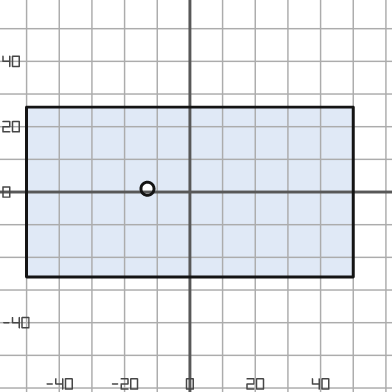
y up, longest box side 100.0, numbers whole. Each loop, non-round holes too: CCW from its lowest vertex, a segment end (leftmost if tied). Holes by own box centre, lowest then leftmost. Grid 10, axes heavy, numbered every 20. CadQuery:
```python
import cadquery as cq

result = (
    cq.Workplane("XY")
    .moveTo(-50.0, -26.0)
    .lineTo(50.0, -26.0)
    .lineTo(50.0, 26.0)
    .lineTo(-50.0, 26.0)
    .close()
    .moveTo(-13.0, 1.0)
    .circle(2.0)
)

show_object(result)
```